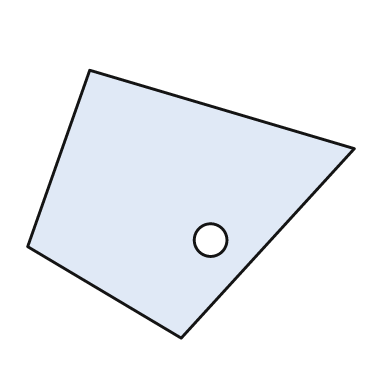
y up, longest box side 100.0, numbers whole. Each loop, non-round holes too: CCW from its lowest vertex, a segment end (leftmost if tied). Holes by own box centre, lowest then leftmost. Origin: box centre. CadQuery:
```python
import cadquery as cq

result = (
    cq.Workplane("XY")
    .moveTo(-3.0, -41.0)
    .lineTo(50.0, 17.0)
    .lineTo(-31.0, 41.0)
    .lineTo(-50.0, -13.0)
    .close()
    .moveTo(6.0, -11.0)
    .circle(5.0)
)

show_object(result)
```